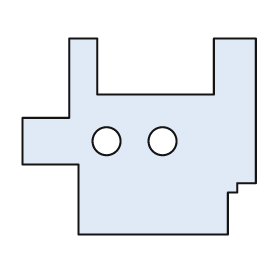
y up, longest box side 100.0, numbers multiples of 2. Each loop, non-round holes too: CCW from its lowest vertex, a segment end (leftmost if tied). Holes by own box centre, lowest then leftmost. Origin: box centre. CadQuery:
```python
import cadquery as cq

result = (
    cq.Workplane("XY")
    .moveTo(-26.0, -42.0)
    .lineTo(38.0, -42.0)
    .lineTo(38.0, -24.0)
    .lineTo(42.0, -24.0)
    .lineTo(42.0, -20.0)
    .lineTo(50.0, -20.0)
    .lineTo(50.0, 42.0)
    .lineTo(32.0, 42.0)
    .lineTo(32.0, 18.0)
    .lineTo(-18.0, 18.0)
    .lineTo(-18.0, 42.0)
    .lineTo(-30.0, 42.0)
    .lineTo(-30.0, 8.0)
    .lineTo(-50.0, 8.0)
    .lineTo(-50.0, -12.0)
    .lineTo(-26.0, -12.0)
    .close()
    .moveTo(-14.0, -2.0)
    .circle(6.0)
    .moveTo(10.0, -2.0)
    .circle(6.0)
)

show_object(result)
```